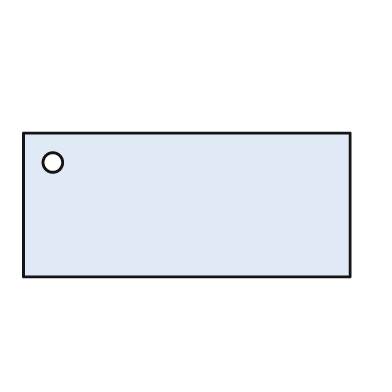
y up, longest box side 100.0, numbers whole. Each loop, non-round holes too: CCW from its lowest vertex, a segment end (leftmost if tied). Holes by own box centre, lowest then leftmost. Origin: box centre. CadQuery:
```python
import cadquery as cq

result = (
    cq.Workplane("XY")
    .moveTo(-50.0, -22.0)
    .lineTo(50.0, -22.0)
    .lineTo(50.0, 22.0)
    .lineTo(-50.0, 22.0)
    .close()
    .moveTo(-41.0, 13.0)
    .circle(3.0)
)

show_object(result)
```